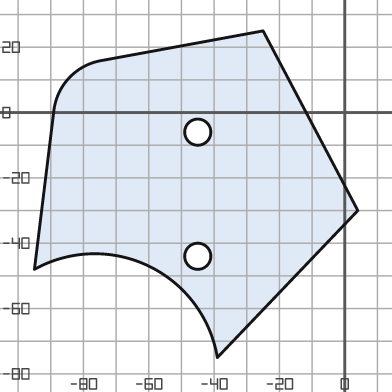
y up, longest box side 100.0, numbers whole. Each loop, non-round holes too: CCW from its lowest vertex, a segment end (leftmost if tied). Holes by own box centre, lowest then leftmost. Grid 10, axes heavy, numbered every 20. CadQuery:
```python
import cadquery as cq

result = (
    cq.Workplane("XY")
    .moveTo(-39.0, -75.0)
    .lineTo(4.0, -30.0)
    .lineTo(-25.0, 25.0)
    .lineTo(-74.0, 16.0)
    .threePointArc((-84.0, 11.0), (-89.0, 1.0))
    .lineTo(-95.0, -48.0)
    .threePointArc((-60.0, -47.0), (-39.0, -75.0))
    .close()
    .moveTo(-45.0, -44.0)
    .circle(4.0)
    .moveTo(-45.0, -6.0)
    .circle(4.0)
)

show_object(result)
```